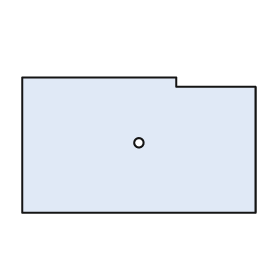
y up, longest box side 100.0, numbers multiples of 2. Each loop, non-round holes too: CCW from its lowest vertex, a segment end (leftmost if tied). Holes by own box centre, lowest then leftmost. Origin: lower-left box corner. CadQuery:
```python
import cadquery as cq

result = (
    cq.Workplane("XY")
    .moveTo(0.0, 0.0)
    .lineTo(100.0, 0.0)
    .lineTo(100.0, 54.0)
    .lineTo(66.0, 54.0)
    .lineTo(66.0, 58.0)
    .lineTo(0.0, 58.0)
    .close()
    .moveTo(50.0, 30.0)
    .circle(2.0)
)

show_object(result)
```